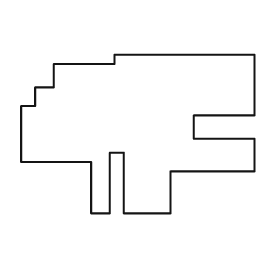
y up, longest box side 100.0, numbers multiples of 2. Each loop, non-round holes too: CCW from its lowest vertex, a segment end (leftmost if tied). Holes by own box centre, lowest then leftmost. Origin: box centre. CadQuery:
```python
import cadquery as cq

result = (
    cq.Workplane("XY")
    .moveTo(-20.0, -34.0)
    .lineTo(-12.0, -34.0)
    .lineTo(-12.0, -8.0)
    .lineTo(-6.0, -8.0)
    .lineTo(-6.0, -34.0)
    .lineTo(14.0, -34.0)
    .lineTo(14.0, -16.0)
    .lineTo(50.0, -16.0)
    .lineTo(50.0, -2.0)
    .lineTo(24.0, -2.0)
    .lineTo(24.0, 8.0)
    .lineTo(50.0, 8.0)
    .lineTo(50.0, 34.0)
    .lineTo(-10.0, 34.0)
    .lineTo(-10.0, 30.0)
    .lineTo(-36.0, 30.0)
    .lineTo(-36.0, 20.0)
    .lineTo(-44.0, 20.0)
    .lineTo(-44.0, 12.0)
    .lineTo(-50.0, 12.0)
    .lineTo(-50.0, -12.0)
    .lineTo(-20.0, -12.0)
    .close()
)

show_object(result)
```